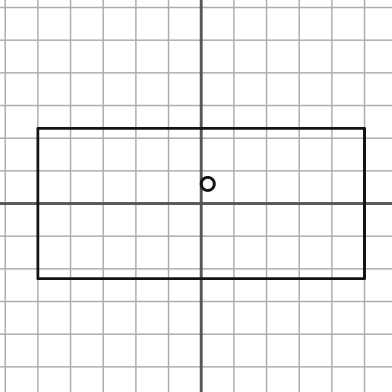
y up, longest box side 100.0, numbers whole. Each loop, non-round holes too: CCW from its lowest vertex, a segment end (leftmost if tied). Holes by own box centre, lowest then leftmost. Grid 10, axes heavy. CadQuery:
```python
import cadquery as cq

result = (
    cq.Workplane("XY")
    .moveTo(-50.0, -23.0)
    .lineTo(50.0, -23.0)
    .lineTo(50.0, 23.0)
    .lineTo(-50.0, 23.0)
    .close()
    .moveTo(2.0, 6.0)
    .circle(2.0)
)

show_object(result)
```